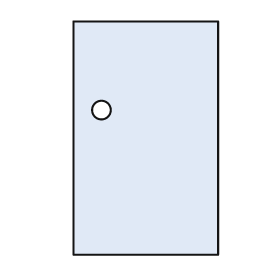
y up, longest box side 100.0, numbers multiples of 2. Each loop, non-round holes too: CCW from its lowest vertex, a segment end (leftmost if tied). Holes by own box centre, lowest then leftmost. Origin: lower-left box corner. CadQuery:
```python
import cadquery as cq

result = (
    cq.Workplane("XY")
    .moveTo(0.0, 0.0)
    .lineTo(62.0, 0.0)
    .lineTo(62.0, 100.0)
    .lineTo(0.0, 100.0)
    .close()
    .moveTo(12.0, 62.0)
    .circle(4.0)
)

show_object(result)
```